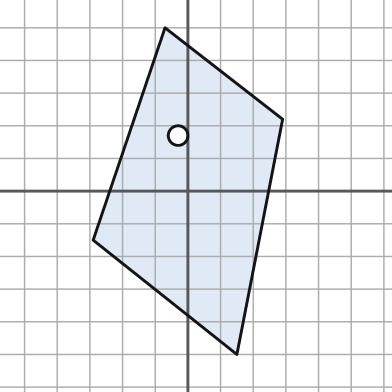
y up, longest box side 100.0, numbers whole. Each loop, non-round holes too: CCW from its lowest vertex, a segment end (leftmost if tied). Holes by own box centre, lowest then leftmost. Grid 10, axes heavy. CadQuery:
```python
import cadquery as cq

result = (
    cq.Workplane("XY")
    .moveTo(15.0, -50.0)
    .lineTo(29.0, 22.0)
    .lineTo(-7.0, 50.0)
    .lineTo(-29.0, -15.0)
    .close()
    .moveTo(-3.0, 17.0)
    .circle(3.0)
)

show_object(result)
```